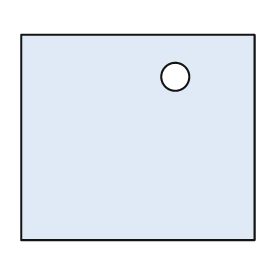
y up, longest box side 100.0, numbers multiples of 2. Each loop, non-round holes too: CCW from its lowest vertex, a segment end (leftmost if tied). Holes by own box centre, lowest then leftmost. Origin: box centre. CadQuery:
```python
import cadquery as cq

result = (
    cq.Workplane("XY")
    .moveTo(-50.0, -44.0)
    .lineTo(50.0, -44.0)
    .lineTo(50.0, 44.0)
    .lineTo(-50.0, 44.0)
    .close()
    .moveTo(16.0, 26.0)
    .circle(6.0)
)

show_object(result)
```